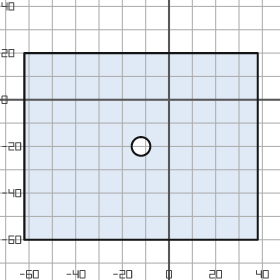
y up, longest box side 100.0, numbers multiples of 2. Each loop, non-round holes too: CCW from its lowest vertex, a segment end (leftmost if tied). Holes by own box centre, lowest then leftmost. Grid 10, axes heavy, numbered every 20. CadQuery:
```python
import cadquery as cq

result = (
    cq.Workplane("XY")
    .moveTo(-62.0, -60.0)
    .lineTo(38.0, -60.0)
    .lineTo(38.0, 20.0)
    .lineTo(-62.0, 20.0)
    .close()
    .moveTo(-12.0, -20.0)
    .circle(4.0)
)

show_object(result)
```